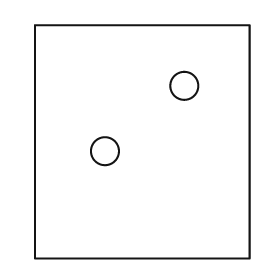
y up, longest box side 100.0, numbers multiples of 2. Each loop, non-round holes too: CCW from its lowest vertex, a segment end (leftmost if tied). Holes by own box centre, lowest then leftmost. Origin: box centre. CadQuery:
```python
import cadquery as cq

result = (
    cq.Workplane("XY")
    .moveTo(-46.0, -50.0)
    .lineTo(46.0, -50.0)
    .lineTo(46.0, 50.0)
    .lineTo(-46.0, 50.0)
    .close()
    .moveTo(-16.0, -4.0)
    .circle(6.0)
    .moveTo(18.0, 24.0)
    .circle(6.0)
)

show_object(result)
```